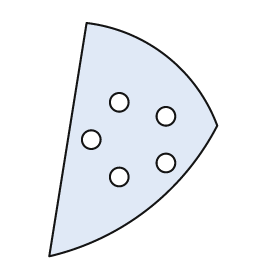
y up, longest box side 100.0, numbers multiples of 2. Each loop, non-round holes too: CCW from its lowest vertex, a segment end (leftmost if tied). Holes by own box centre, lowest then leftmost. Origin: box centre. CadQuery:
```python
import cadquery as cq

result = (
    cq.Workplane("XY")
    .moveTo(-36.0, -50.0)
    .threePointArc((6.0, -30.0), (36.0, 6.0))
    .threePointArc((14.0, 36.0), (-20.0, 50.0))
    .close()
    .moveTo(-6.0, -16.0)
    .circle(4.0)
    .moveTo(14.0, -10.0)
    .circle(4.0)
    .moveTo(-18.0, 0.0)
    .circle(4.0)
    .moveTo(14.0, 10.0)
    .circle(4.0)
    .moveTo(-6.0, 16.0)
    .circle(4.0)
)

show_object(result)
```